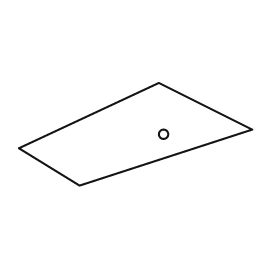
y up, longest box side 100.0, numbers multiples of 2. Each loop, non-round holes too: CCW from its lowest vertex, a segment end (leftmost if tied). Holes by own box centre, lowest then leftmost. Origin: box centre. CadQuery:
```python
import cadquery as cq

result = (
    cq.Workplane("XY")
    .moveTo(-24.0, -22.0)
    .lineTo(50.0, 2.0)
    .lineTo(10.0, 22.0)
    .lineTo(-50.0, -6.0)
    .close()
    .moveTo(12.0, 0.0)
    .circle(2.0)
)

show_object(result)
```